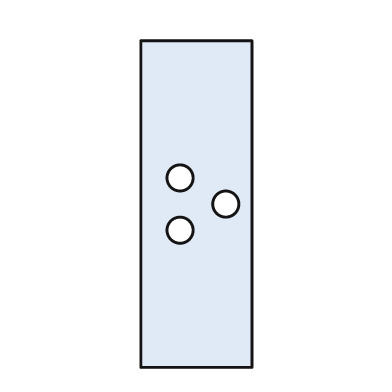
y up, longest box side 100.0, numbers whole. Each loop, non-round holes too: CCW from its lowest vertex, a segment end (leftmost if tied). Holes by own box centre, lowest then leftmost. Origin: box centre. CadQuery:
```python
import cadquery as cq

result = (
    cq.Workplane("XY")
    .moveTo(-17.0, -50.0)
    .lineTo(17.0, -50.0)
    .lineTo(17.0, 50.0)
    .lineTo(-17.0, 50.0)
    .close()
    .moveTo(-5.0, -8.0)
    .circle(4.0)
    .moveTo(9.0, 0.0)
    .circle(4.0)
    .moveTo(-5.0, 8.0)
    .circle(4.0)
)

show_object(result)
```